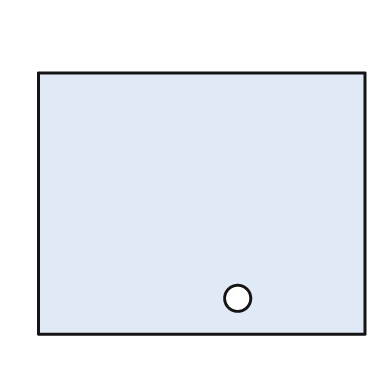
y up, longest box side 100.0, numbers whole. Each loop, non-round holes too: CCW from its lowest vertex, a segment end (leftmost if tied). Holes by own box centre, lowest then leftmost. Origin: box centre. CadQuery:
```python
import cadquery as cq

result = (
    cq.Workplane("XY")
    .moveTo(-50.0, -40.0)
    .lineTo(50.0, -40.0)
    .lineTo(50.0, 40.0)
    .lineTo(-50.0, 40.0)
    .close()
    .moveTo(11.0, -29.0)
    .circle(4.0)
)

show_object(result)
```